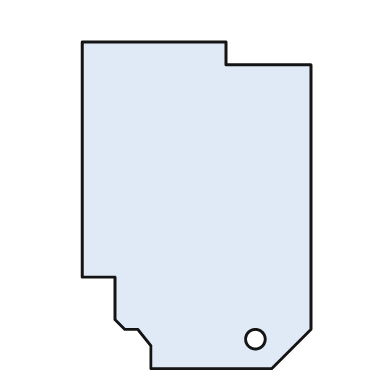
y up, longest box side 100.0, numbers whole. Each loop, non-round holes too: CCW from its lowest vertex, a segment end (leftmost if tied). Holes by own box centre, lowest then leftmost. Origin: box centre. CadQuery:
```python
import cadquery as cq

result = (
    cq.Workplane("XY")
    .moveTo(-14.0, -50.0)
    .lineTo(23.0, -50.0)
    .lineTo(35.0, -38.0)
    .lineTo(35.0, 43.0)
    .lineTo(9.0, 43.0)
    .lineTo(9.0, 50.0)
    .lineTo(-35.0, 50.0)
    .lineTo(-35.0, -22.0)
    .lineTo(-25.0, -22.0)
    .lineTo(-25.0, -35.0)
    .lineTo(-22.0, -38.0)
    .lineTo(-18.0, -38.0)
    .lineTo(-14.0, -43.0)
    .close()
    .moveTo(18.0, -41.0)
    .circle(3.0)
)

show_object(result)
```